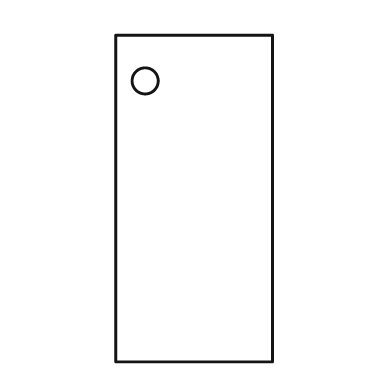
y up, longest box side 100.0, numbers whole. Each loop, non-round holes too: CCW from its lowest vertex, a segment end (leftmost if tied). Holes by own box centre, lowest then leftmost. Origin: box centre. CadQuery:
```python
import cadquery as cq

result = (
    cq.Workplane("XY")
    .moveTo(-24.0, -50.0)
    .lineTo(24.0, -50.0)
    .lineTo(24.0, 50.0)
    .lineTo(-24.0, 50.0)
    .close()
    .moveTo(-15.0, 36.0)
    .circle(4.0)
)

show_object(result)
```